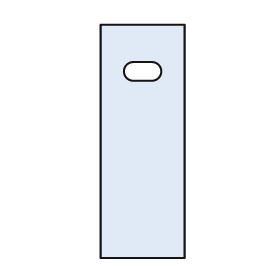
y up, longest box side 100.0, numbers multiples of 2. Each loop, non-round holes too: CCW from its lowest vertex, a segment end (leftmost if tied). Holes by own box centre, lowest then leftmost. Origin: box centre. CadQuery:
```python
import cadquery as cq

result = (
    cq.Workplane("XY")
    .moveTo(-18.0, -50.0)
    .lineTo(18.0, -50.0)
    .lineTo(18.0, 50.0)
    .lineTo(-18.0, 50.0)
    .close()
    .moveTo(-4.0, 26.0)
    .lineTo(4.0, 26.0)
    .threePointArc((8.0, 30.0), (4.0, 34.0))
    .lineTo(-4.0, 34.0)
    .threePointArc((-8.0, 30.0), (-4.0, 26.0))
    .close()
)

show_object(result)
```